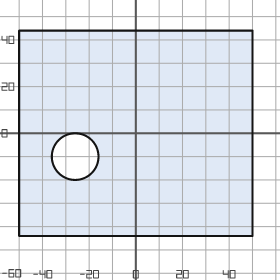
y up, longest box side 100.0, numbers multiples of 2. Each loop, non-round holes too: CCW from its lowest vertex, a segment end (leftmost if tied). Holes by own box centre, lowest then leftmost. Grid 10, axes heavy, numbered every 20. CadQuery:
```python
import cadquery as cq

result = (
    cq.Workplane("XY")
    .moveTo(-50.0, -44.0)
    .lineTo(50.0, -44.0)
    .lineTo(50.0, 44.0)
    .lineTo(-50.0, 44.0)
    .close()
    .moveTo(-26.0, -10.0)
    .circle(10.0)
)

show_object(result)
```